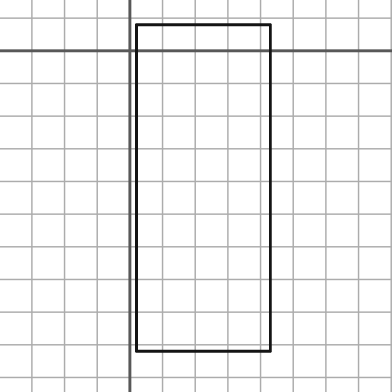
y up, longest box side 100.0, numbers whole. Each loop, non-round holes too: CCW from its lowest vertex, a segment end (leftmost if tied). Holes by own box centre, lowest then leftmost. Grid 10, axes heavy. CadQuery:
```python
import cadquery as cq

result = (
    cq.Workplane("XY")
    .moveTo(2.0, -92.0)
    .lineTo(43.0, -92.0)
    .lineTo(43.0, 8.0)
    .lineTo(2.0, 8.0)
    .close()
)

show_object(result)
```